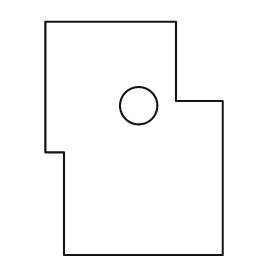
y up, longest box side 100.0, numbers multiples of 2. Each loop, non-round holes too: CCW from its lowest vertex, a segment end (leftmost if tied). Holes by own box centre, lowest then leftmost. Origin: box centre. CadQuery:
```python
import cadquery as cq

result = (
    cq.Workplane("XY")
    .moveTo(-30.0, -50.0)
    .lineTo(38.0, -50.0)
    .lineTo(38.0, 16.0)
    .lineTo(18.0, 16.0)
    .lineTo(18.0, 50.0)
    .lineTo(-38.0, 50.0)
    .lineTo(-38.0, -6.0)
    .lineTo(-30.0, -6.0)
    .close()
    .moveTo(2.0, 14.0)
    .circle(8.0)
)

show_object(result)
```